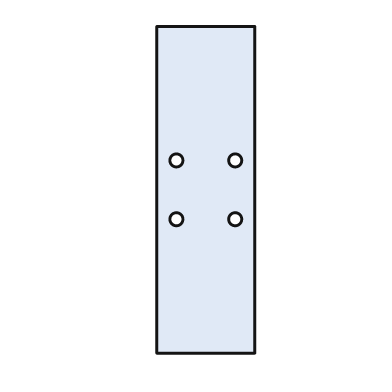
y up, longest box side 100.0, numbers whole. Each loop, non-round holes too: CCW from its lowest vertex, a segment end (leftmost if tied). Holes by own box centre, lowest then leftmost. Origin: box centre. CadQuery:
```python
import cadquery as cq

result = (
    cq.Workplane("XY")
    .moveTo(-15.0, -50.0)
    .lineTo(15.0, -50.0)
    .lineTo(15.0, 50.0)
    .lineTo(-15.0, 50.0)
    .close()
    .moveTo(-9.0, -9.0)
    .circle(2.0)
    .moveTo(9.0, -9.0)
    .circle(2.0)
    .moveTo(-9.0, 9.0)
    .circle(2.0)
    .moveTo(9.0, 9.0)
    .circle(2.0)
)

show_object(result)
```